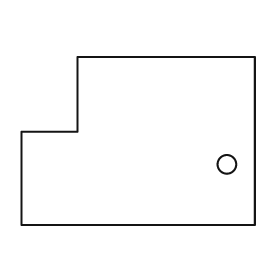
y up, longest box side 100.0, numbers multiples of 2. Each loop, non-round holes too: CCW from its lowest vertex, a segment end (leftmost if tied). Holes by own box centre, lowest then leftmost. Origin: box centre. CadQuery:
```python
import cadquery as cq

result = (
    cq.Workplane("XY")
    .moveTo(-50.0, -36.0)
    .lineTo(50.0, -36.0)
    .lineTo(50.0, 36.0)
    .lineTo(-26.0, 36.0)
    .lineTo(-26.0, 4.0)
    .lineTo(-50.0, 4.0)
    .close()
    .moveTo(38.0, -10.0)
    .circle(4.0)
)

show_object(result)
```